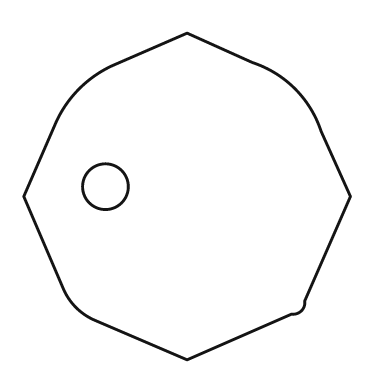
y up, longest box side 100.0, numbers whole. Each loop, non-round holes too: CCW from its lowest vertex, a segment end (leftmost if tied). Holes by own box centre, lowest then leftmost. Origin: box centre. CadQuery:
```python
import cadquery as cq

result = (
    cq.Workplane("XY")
    .moveTo(0.0, -50.0)
    .lineTo(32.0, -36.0)
    .threePointArc((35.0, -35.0), (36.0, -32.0))
    .lineTo(50.0, 0.0)
    .lineTo(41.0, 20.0)
    .threePointArc((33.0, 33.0), (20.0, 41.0))
    .lineTo(0.0, 50.0)
    .lineTo(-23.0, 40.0)
    .threePointArc((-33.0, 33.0), (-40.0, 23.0))
    .lineTo(-50.0, 0.0)
    .lineTo(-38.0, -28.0)
    .threePointArc((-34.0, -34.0), (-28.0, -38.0))
    .close()
    .moveTo(-25.0, 3.0)
    .circle(7.0)
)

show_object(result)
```